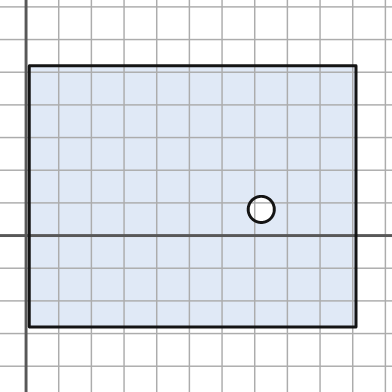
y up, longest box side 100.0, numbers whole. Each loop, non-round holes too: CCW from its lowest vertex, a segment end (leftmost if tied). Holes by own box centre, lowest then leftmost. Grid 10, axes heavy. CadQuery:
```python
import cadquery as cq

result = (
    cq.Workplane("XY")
    .moveTo(1.0, -28.0)
    .lineTo(101.0, -28.0)
    .lineTo(101.0, 52.0)
    .lineTo(1.0, 52.0)
    .close()
    .moveTo(72.0, 8.0)
    .circle(4.0)
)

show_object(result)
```